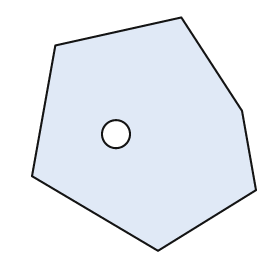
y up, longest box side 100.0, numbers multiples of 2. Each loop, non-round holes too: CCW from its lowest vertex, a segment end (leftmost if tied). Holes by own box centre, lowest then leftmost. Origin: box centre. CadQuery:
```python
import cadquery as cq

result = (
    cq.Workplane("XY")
    .moveTo(6.0, -50.0)
    .lineTo(48.0, -24.0)
    .lineTo(42.0, 10.0)
    .lineTo(16.0, 50.0)
    .lineTo(-38.0, 38.0)
    .lineTo(-48.0, -18.0)
    .close()
    .moveTo(-12.0, 0.0)
    .circle(6.0)
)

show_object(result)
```